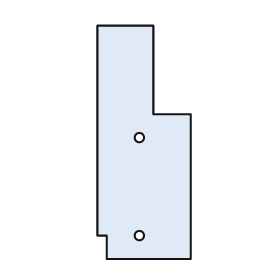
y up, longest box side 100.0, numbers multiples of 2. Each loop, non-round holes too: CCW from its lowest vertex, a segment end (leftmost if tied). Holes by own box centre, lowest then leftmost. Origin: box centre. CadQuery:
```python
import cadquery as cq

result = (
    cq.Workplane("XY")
    .moveTo(-16.0, -50.0)
    .lineTo(20.0, -50.0)
    .lineTo(20.0, 12.0)
    .lineTo(4.0, 12.0)
    .lineTo(4.0, 50.0)
    .lineTo(-20.0, 50.0)
    .lineTo(-20.0, -40.0)
    .lineTo(-16.0, -40.0)
    .close()
    .moveTo(-2.0, -40.0)
    .circle(2.0)
    .moveTo(-2.0, 2.0)
    .circle(2.0)
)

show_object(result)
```